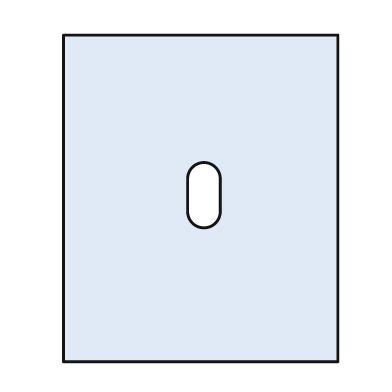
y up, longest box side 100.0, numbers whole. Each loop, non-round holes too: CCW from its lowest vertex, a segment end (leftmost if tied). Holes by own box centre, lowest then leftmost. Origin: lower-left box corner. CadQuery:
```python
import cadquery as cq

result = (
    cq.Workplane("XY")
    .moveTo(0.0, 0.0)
    .lineTo(84.0, 0.0)
    .lineTo(84.0, 100.0)
    .lineTo(0.0, 100.0)
    .close()
    .moveTo(38.0, 46.0)
    .threePointArc((43.0, 41.0), (48.0, 46.0))
    .lineTo(48.0, 56.0)
    .threePointArc((43.0, 61.0), (38.0, 56.0))
    .close()
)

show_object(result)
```